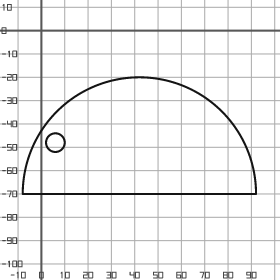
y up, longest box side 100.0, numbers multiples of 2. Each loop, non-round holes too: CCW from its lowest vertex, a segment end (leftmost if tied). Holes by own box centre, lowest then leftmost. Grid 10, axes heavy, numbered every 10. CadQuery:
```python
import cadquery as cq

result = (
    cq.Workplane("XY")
    .moveTo(-8.0, -70.0)
    .lineTo(92.0, -70.0)
    .threePointArc((42.0, -20.0), (-8.0, -70.0))
    .close()
    .moveTo(6.0, -48.0)
    .circle(4.0)
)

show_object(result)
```